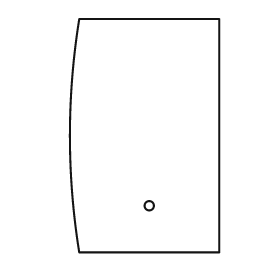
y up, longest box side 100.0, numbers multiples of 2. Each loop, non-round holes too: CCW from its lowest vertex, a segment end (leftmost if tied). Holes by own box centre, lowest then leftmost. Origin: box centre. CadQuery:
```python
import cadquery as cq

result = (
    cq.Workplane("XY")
    .moveTo(-28.0, -50.0)
    .lineTo(32.0, -50.0)
    .lineTo(32.0, 50.0)
    .lineTo(-28.0, 50.0)
    .threePointArc((-32.0, 0.0), (-28.0, -50.0))
    .close()
    .moveTo(2.0, -30.0)
    .circle(2.0)
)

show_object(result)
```